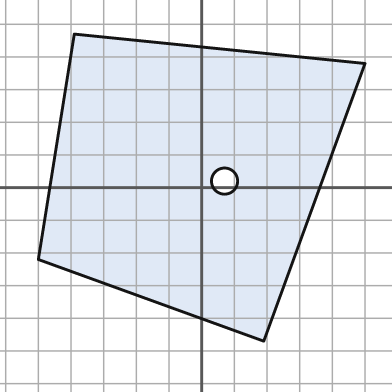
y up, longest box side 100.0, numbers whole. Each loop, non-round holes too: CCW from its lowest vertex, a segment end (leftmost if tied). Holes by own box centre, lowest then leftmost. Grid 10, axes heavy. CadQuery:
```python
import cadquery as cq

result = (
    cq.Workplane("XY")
    .moveTo(19.0, -47.0)
    .lineTo(50.0, 38.0)
    .lineTo(-39.0, 47.0)
    .lineTo(-50.0, -22.0)
    .close()
    .moveTo(7.0, 2.0)
    .circle(4.0)
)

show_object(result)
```